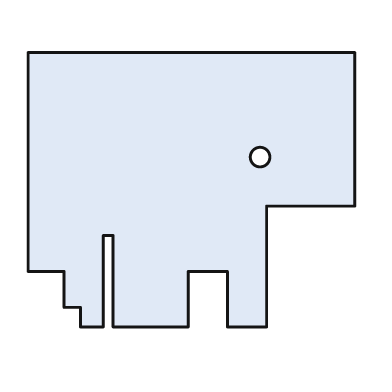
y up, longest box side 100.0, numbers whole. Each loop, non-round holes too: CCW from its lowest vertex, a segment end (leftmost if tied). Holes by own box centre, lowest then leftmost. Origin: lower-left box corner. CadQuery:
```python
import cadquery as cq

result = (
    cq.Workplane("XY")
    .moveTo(16.0, 0.0)
    .lineTo(23.0, 0.0)
    .lineTo(23.0, 28.0)
    .lineTo(26.0, 28.0)
    .lineTo(26.0, 0.0)
    .lineTo(49.0, 0.0)
    .lineTo(49.0, 17.0)
    .lineTo(61.0, 17.0)
    .lineTo(61.0, 0.0)
    .lineTo(73.0, 0.0)
    .lineTo(73.0, 37.0)
    .lineTo(100.0, 37.0)
    .lineTo(100.0, 84.0)
    .lineTo(0.0, 84.0)
    .lineTo(0.0, 17.0)
    .lineTo(11.0, 17.0)
    .lineTo(11.0, 6.0)
    .lineTo(16.0, 6.0)
    .close()
    .moveTo(71.0, 52.0)
    .circle(3.0)
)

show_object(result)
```